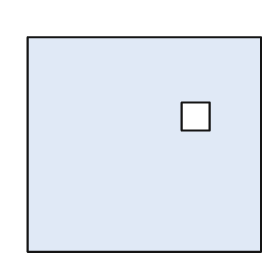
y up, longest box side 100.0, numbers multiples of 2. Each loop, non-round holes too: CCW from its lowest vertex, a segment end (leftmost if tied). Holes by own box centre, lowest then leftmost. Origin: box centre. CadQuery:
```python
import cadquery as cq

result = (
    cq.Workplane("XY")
    .moveTo(-50.0, -46.0)
    .lineTo(50.0, -46.0)
    .lineTo(50.0, 46.0)
    .lineTo(-50.0, 46.0)
    .close()
    .moveTo(16.0, 6.0)
    .lineTo(28.0, 6.0)
    .lineTo(28.0, 18.0)
    .lineTo(16.0, 18.0)
    .close()
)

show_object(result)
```